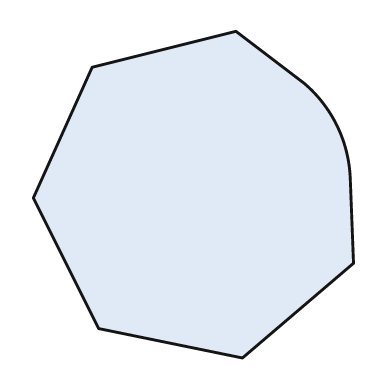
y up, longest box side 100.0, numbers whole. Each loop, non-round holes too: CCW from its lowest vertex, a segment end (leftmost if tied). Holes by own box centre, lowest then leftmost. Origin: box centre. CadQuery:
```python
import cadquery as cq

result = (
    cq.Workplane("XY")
    .moveTo(15.0, -50.0)
    .lineTo(49.0, -21.0)
    .lineTo(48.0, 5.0)
    .threePointArc((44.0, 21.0), (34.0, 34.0))
    .lineTo(13.0, 50.0)
    .lineTo(-31.0, 39.0)
    .lineTo(-49.0, -1.0)
    .lineTo(-29.0, -41.0)
    .close()
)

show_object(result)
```